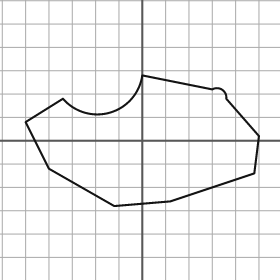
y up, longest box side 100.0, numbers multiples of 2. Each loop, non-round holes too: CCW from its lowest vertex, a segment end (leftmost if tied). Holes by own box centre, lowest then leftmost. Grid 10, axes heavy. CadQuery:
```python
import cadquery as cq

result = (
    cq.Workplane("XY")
    .moveTo(-12.0, -28.0)
    .lineTo(12.0, -26.0)
    .lineTo(48.0, -14.0)
    .lineTo(50.0, 2.0)
    .lineTo(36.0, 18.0)
    .threePointArc((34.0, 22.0), (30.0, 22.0))
    .lineTo(0.0, 28.0)
    .threePointArc((-14.0, 12.0), (-34.0, 18.0))
    .lineTo(-50.0, 8.0)
    .lineTo(-40.0, -12.0)
    .close()
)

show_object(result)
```